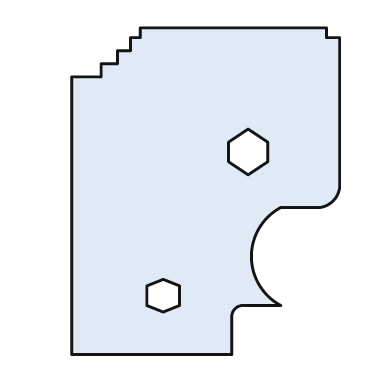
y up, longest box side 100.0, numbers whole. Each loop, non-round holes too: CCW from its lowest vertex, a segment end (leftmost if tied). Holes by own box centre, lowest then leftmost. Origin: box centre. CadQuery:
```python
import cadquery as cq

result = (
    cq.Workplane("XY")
    .moveTo(-41.0, -50.0)
    .lineTo(8.0, -50.0)
    .lineTo(8.0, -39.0)
    .threePointArc((9.0, -36.0), (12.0, -35.0))
    .lineTo(23.0, -35.0)
    .threePointArc((14.0, -20.0), (23.0, -5.0))
    .lineTo(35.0, -5.0)
    .threePointArc((39.0, -3.0), (41.0, 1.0))
    .lineTo(41.0, 47.0)
    .lineTo(37.0, 47.0)
    .lineTo(37.0, 50.0)
    .lineTo(-20.0, 50.0)
    .lineTo(-20.0, 47.0)
    .lineTo(-23.0, 47.0)
    .lineTo(-23.0, 43.0)
    .lineTo(-27.0, 43.0)
    .lineTo(-27.0, 39.0)
    .lineTo(-32.0, 39.0)
    .lineTo(-32.0, 35.0)
    .lineTo(-41.0, 35.0)
    .close()
    .moveTo(-13.0, -37.0)
    .lineTo(-8.0, -35.0)
    .lineTo(-8.0, -29.0)
    .lineTo(-13.0, -27.0)
    .lineTo(-18.0, -29.0)
    .lineTo(-18.0, -35.0)
    .close()
    .moveTo(13.0, 5.0)
    .lineTo(19.0, 9.0)
    .lineTo(19.0, 15.0)
    .lineTo(13.0, 19.0)
    .lineTo(7.0, 15.0)
    .lineTo(7.0, 9.0)
    .close()
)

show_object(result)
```